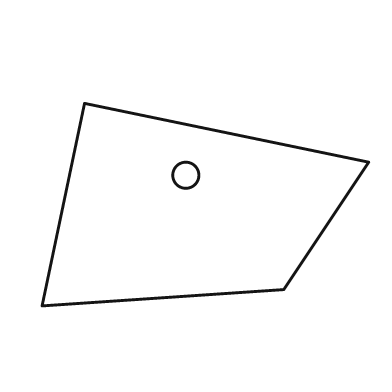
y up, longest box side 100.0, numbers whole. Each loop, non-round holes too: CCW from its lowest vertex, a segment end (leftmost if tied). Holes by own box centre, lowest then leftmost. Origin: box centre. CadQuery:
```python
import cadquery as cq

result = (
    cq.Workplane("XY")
    .moveTo(-50.0, -31.0)
    .lineTo(24.0, -26.0)
    .lineTo(50.0, 13.0)
    .lineTo(-37.0, 31.0)
    .close()
    .moveTo(-6.0, 9.0)
    .circle(4.0)
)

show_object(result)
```